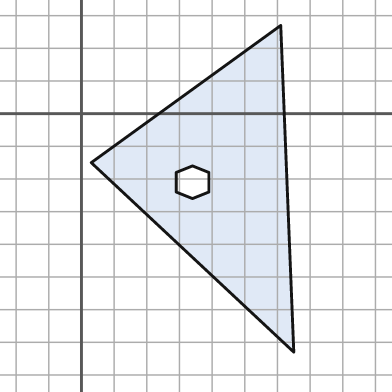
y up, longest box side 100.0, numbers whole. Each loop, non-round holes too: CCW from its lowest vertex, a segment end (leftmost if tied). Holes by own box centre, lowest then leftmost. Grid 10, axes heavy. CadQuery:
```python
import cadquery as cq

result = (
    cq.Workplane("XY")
    .moveTo(65.0, -73.0)
    .lineTo(61.0, 27.0)
    .lineTo(3.0, -15.0)
    .close()
    .moveTo(34.0, -26.0)
    .lineTo(39.0, -24.0)
    .lineTo(39.0, -18.0)
    .lineTo(34.0, -16.0)
    .lineTo(29.0, -18.0)
    .lineTo(29.0, -24.0)
    .close()
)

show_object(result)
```